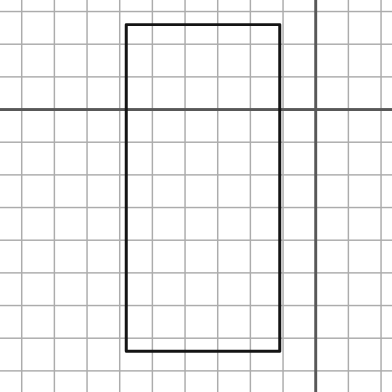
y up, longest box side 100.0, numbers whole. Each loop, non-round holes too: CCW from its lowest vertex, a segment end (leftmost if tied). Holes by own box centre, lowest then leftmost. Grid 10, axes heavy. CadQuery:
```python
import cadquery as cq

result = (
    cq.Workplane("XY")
    .moveTo(-58.0, -74.0)
    .lineTo(-11.0, -74.0)
    .lineTo(-11.0, 26.0)
    .lineTo(-58.0, 26.0)
    .close()
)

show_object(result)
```